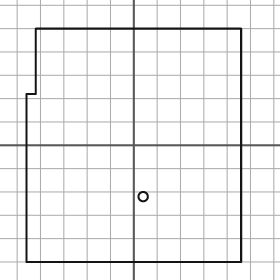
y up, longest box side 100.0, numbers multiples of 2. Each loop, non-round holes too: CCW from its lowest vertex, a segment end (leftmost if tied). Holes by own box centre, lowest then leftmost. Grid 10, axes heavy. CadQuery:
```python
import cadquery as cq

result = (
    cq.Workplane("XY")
    .moveTo(-46.0, -50.0)
    .lineTo(46.0, -50.0)
    .lineTo(46.0, 50.0)
    .lineTo(-42.0, 50.0)
    .lineTo(-42.0, 22.0)
    .lineTo(-46.0, 22.0)
    .close()
    .moveTo(4.0, -22.0)
    .circle(2.0)
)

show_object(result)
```